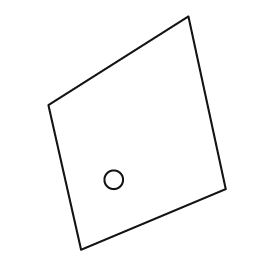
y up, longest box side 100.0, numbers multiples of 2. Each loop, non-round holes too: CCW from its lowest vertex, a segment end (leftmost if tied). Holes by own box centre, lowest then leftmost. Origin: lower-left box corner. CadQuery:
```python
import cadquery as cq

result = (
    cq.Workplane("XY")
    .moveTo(14.0, 0.0)
    .lineTo(76.0, 26.0)
    .lineTo(60.0, 100.0)
    .lineTo(0.0, 62.0)
    .close()
    .moveTo(28.0, 30.0)
    .circle(4.0)
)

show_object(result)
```